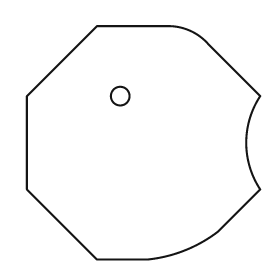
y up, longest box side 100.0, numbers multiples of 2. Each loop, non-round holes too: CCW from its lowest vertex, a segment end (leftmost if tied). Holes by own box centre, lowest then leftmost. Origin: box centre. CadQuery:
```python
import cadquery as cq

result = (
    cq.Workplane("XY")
    .moveTo(-20.0, -50.0)
    .lineTo(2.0, -50.0)
    .threePointArc((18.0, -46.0), (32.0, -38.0))
    .lineTo(50.0, -20.0)
    .threePointArc((44.0, 0.0), (50.0, 20.0))
    .lineTo(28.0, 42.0)
    .threePointArc((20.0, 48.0), (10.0, 50.0))
    .lineTo(-20.0, 50.0)
    .lineTo(-50.0, 20.0)
    .lineTo(-50.0, -20.0)
    .close()
    .moveTo(-10.0, 20.0)
    .circle(4.0)
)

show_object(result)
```